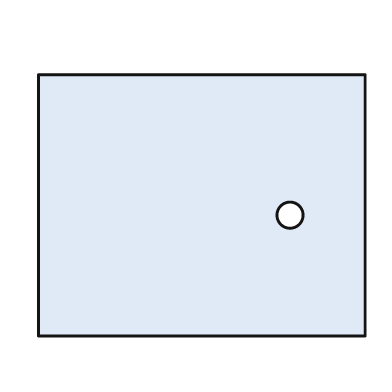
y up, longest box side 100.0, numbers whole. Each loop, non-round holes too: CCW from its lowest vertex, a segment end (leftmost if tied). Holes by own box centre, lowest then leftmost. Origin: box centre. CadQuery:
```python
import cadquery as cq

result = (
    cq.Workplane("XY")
    .moveTo(-50.0, -40.0)
    .lineTo(50.0, -40.0)
    .lineTo(50.0, 40.0)
    .lineTo(-50.0, 40.0)
    .close()
    .moveTo(27.0, -3.0)
    .circle(4.0)
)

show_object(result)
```